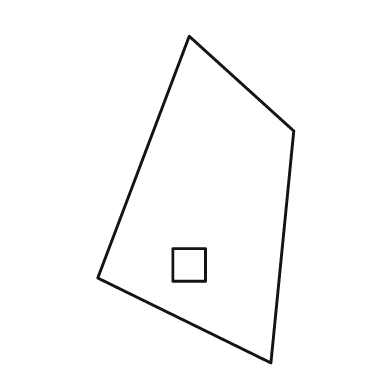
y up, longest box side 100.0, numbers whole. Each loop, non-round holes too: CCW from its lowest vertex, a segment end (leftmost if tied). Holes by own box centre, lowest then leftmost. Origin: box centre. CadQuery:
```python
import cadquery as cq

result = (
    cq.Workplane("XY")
    .moveTo(23.0, -50.0)
    .lineTo(30.0, 21.0)
    .lineTo(-2.0, 50.0)
    .lineTo(-30.0, -24.0)
    .close()
    .moveTo(-7.0, -25.0)
    .lineTo(3.0, -25.0)
    .lineTo(3.0, -15.0)
    .lineTo(-7.0, -15.0)
    .close()
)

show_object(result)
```